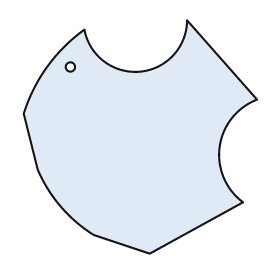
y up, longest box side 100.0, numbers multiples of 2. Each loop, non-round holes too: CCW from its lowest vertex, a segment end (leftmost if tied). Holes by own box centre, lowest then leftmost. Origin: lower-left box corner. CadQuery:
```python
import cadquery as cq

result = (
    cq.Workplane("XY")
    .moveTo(54.0, 0.0)
    .lineTo(94.0, 22.0)
    .threePointArc((84.0, 46.0), (100.0, 66.0))
    .lineTo(70.0, 100.0)
    .threePointArc((50.0, 78.0), (26.0, 96.0))
    .threePointArc((10.0, 80.0), (0.0, 60.0))
    .lineTo(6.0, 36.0)
    .threePointArc((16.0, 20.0), (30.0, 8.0))
    .close()
    .moveTo(20.0, 80.0)
    .circle(2.0)
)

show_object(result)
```